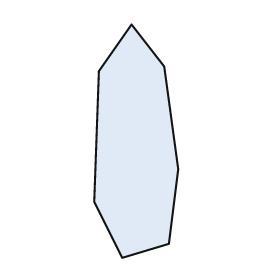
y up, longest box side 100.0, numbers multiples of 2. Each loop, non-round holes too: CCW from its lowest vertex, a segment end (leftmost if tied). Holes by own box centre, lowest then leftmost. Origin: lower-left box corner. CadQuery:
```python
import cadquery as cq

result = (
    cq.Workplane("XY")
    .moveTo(12.0, 0.0)
    .lineTo(32.0, 6.0)
    .lineTo(36.0, 38.0)
    .lineTo(30.0, 82.0)
    .lineTo(16.0, 100.0)
    .lineTo(2.0, 80.0)
    .lineTo(0.0, 24.0)
    .close()
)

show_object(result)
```